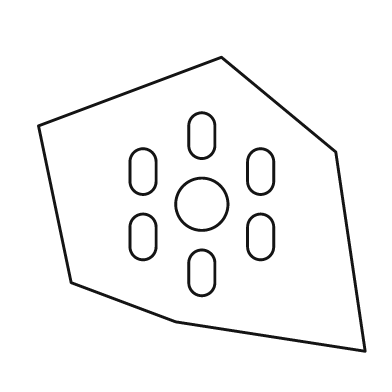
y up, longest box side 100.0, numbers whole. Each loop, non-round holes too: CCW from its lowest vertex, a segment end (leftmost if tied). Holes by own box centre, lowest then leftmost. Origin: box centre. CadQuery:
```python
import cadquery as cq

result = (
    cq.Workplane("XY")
    .moveTo(50.0, -45.0)
    .lineTo(41.0, 16.0)
    .lineTo(6.0, 45.0)
    .lineTo(-50.0, 24.0)
    .lineTo(-40.0, -24.0)
    .lineTo(-8.0, -36.0)
    .close()
    .moveTo(-4.0, -24.0)
    .threePointArc((0.0, -28.0), (4.0, -24.0))
    .lineTo(4.0, -18.0)
    .threePointArc((0.0, -14.0), (-4.0, -18.0))
    .close()
    .moveTo(-22.0, -13.0)
    .threePointArc((-18.0, -17.0), (-14.0, -13.0))
    .lineTo(-14.0, -7.0)
    .threePointArc((-18.0, -3.0), (-22.0, -7.0))
    .close()
    .moveTo(14.0, -13.0)
    .threePointArc((18.0, -17.0), (22.0, -13.0))
    .lineTo(22.0, -7.0)
    .threePointArc((18.0, -3.0), (14.0, -7.0))
    .close()
    .moveTo(0.0, 0.0)
    .circle(8.0)
    .moveTo(-22.0, 7.0)
    .threePointArc((-18.0, 3.0), (-14.0, 7.0))
    .lineTo(-14.0, 13.0)
    .threePointArc((-18.0, 17.0), (-22.0, 13.0))
    .close()
    .moveTo(14.0, 7.0)
    .threePointArc((18.0, 3.0), (22.0, 7.0))
    .lineTo(22.0, 13.0)
    .threePointArc((18.0, 17.0), (14.0, 13.0))
    .close()
    .moveTo(-4.0, 18.0)
    .threePointArc((0.0, 14.0), (4.0, 18.0))
    .lineTo(4.0, 24.0)
    .threePointArc((0.0, 28.0), (-4.0, 24.0))
    .close()
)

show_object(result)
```